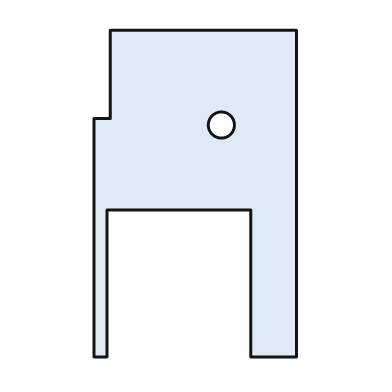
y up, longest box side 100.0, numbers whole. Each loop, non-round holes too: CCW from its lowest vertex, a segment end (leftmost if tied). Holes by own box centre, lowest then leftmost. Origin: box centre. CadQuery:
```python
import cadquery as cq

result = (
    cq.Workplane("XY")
    .moveTo(-31.0, -50.0)
    .lineTo(-27.0, -50.0)
    .lineTo(-27.0, -5.0)
    .lineTo(17.0, -5.0)
    .lineTo(17.0, -50.0)
    .lineTo(31.0, -50.0)
    .lineTo(31.0, 50.0)
    .lineTo(-26.0, 50.0)
    .lineTo(-26.0, 23.0)
    .lineTo(-31.0, 23.0)
    .close()
    .moveTo(8.0, 21.0)
    .circle(4.0)
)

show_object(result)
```